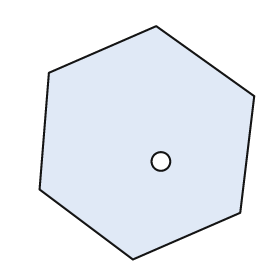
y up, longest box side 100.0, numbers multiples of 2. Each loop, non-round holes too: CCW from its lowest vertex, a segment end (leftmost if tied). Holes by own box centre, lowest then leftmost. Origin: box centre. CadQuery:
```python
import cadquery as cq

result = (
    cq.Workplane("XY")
    .moveTo(-6.0, -50.0)
    .lineTo(40.0, -30.0)
    .lineTo(46.0, 20.0)
    .lineTo(4.0, 50.0)
    .lineTo(-42.0, 30.0)
    .lineTo(-46.0, -20.0)
    .close()
    .moveTo(6.0, -8.0)
    .circle(4.0)
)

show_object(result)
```